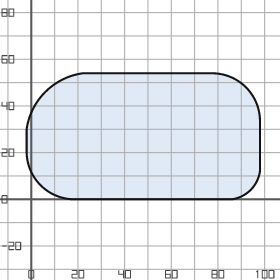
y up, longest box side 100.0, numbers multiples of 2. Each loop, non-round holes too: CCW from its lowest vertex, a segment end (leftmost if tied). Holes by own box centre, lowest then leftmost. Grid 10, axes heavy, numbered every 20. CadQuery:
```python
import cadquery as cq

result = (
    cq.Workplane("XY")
    .moveTo(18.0, 0.0)
    .lineTo(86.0, 0.0)
    .threePointArc((94.0, 4.0), (98.0, 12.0))
    .lineTo(98.0, 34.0)
    .threePointArc((92.0, 48.0), (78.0, 54.0))
    .lineTo(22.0, 54.0)
    .threePointArc((6.0, 46.0), (-2.0, 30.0))
    .lineTo(-2.0, 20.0)
    .threePointArc((4.0, 6.0), (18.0, 0.0))
    .close()
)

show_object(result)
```